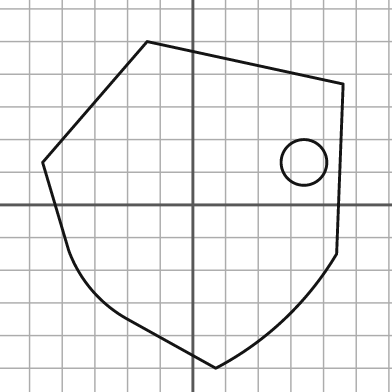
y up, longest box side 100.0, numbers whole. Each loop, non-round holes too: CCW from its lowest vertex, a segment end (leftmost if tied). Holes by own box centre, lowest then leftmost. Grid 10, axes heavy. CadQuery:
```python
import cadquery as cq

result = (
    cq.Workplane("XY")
    .moveTo(7.0, -50.0)
    .threePointArc((28.0, -35.0), (44.0, -15.0))
    .lineTo(46.0, 37.0)
    .lineTo(-14.0, 50.0)
    .lineTo(-46.0, 13.0)
    .lineTo(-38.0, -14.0)
    .threePointArc((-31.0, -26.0), (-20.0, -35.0))
    .close()
    .moveTo(34.0, 13.0)
    .circle(7.0)
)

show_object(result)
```